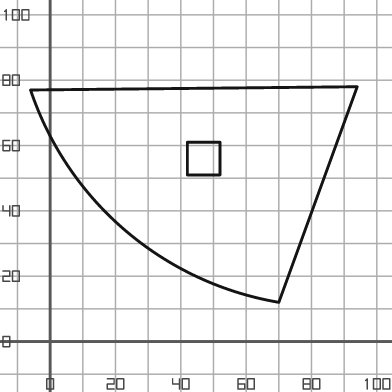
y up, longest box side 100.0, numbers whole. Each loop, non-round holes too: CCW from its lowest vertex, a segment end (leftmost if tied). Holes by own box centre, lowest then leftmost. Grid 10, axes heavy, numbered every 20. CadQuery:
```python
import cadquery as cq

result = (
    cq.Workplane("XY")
    .moveTo(70.0, 12.0)
    .lineTo(94.0, 78.0)
    .lineTo(-6.0, 77.0)
    .threePointArc((23.0, 34.0), (70.0, 12.0))
    .close()
    .moveTo(42.0, 51.0)
    .lineTo(52.0, 51.0)
    .lineTo(52.0, 61.0)
    .lineTo(42.0, 61.0)
    .close()
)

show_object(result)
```